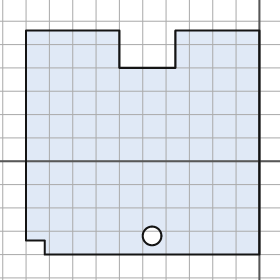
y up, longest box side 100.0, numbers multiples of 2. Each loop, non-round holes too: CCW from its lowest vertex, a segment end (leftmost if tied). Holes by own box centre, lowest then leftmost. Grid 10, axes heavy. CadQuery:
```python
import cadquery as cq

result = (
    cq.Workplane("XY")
    .moveTo(-92.0, -40.0)
    .lineTo(0.0, -40.0)
    .lineTo(0.0, 56.0)
    .lineTo(-36.0, 56.0)
    .lineTo(-36.0, 40.0)
    .lineTo(-60.0, 40.0)
    .lineTo(-60.0, 56.0)
    .lineTo(-100.0, 56.0)
    .lineTo(-100.0, -34.0)
    .lineTo(-92.0, -34.0)
    .close()
    .moveTo(-46.0, -32.0)
    .circle(4.0)
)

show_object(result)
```